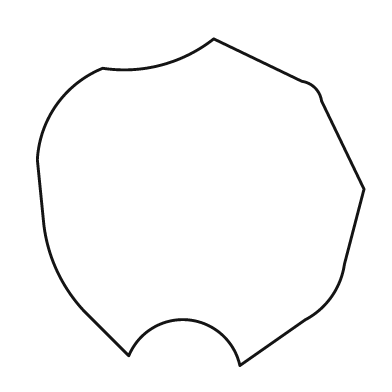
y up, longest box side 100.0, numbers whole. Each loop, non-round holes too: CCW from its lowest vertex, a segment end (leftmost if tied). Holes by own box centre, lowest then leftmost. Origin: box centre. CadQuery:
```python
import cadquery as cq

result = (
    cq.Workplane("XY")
    .moveTo(12.0, -50.0)
    .lineTo(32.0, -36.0)
    .threePointArc((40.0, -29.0), (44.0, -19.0))
    .lineTo(50.0, 4.0)
    .lineTo(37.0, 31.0)
    .threePointArc((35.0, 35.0), (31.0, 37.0))
    .lineTo(4.0, 50.0)
    .threePointArc((-12.0, 42.0), (-30.0, 41.0))
    .threePointArc((-44.0, 30.0), (-50.0, 13.0))
    .lineTo(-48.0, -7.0)
    .threePointArc((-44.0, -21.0), (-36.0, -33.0))
    .lineTo(-22.0, -47.0)
    .threePointArc((-4.0, -36.0), (12.0, -50.0))
    .close()
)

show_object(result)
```